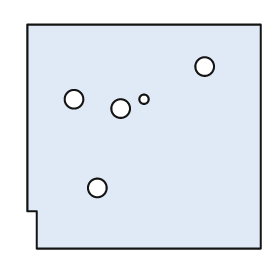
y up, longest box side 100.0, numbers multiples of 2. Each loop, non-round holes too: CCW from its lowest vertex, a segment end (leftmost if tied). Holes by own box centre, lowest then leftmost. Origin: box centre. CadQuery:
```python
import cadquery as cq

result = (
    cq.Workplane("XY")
    .moveTo(-46.0, -48.0)
    .lineTo(50.0, -48.0)
    .lineTo(50.0, 48.0)
    .lineTo(-50.0, 48.0)
    .lineTo(-50.0, -32.0)
    .lineTo(-46.0, -32.0)
    .close()
    .moveTo(-20.0, -22.0)
    .circle(4.0)
    .moveTo(-10.0, 12.0)
    .circle(4.0)
    .moveTo(-30.0, 16.0)
    .circle(4.0)
    .moveTo(0.0, 16.0)
    .circle(2.0)
    .moveTo(26.0, 30.0)
    .circle(4.0)
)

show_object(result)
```